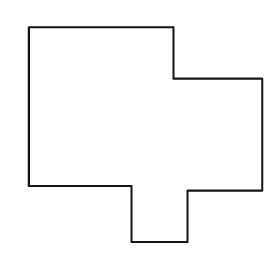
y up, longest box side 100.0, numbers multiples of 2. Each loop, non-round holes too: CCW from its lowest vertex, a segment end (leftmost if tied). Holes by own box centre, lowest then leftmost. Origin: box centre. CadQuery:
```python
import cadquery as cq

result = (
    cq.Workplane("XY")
    .moveTo(-6.0, -46.0)
    .lineTo(18.0, -46.0)
    .lineTo(18.0, -24.0)
    .lineTo(50.0, -24.0)
    .lineTo(50.0, 24.0)
    .lineTo(12.0, 24.0)
    .lineTo(12.0, 46.0)
    .lineTo(-50.0, 46.0)
    .lineTo(-50.0, -22.0)
    .lineTo(-6.0, -22.0)
    .close()
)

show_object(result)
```